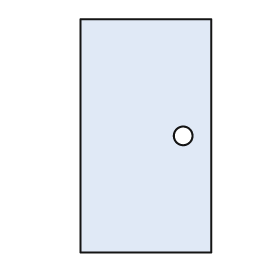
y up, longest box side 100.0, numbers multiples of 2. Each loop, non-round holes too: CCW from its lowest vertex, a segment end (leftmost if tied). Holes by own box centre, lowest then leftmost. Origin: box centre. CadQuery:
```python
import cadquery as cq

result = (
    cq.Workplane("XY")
    .moveTo(-28.0, -50.0)
    .lineTo(28.0, -50.0)
    .lineTo(28.0, 50.0)
    .lineTo(-28.0, 50.0)
    .close()
    .moveTo(16.0, 0.0)
    .circle(4.0)
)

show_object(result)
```